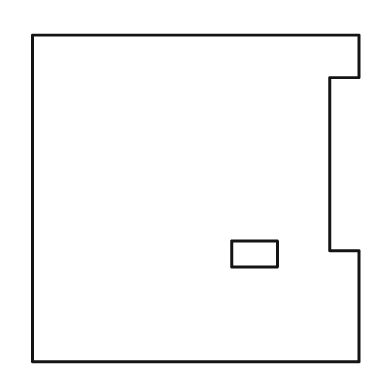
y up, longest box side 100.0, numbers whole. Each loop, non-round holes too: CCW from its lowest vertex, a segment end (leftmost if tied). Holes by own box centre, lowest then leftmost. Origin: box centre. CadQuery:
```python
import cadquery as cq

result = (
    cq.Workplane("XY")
    .moveTo(-50.0, -50.0)
    .lineTo(50.0, -50.0)
    .lineTo(50.0, -16.0)
    .lineTo(41.0, -16.0)
    .lineTo(41.0, 37.0)
    .lineTo(50.0, 37.0)
    .lineTo(50.0, 50.0)
    .lineTo(-50.0, 50.0)
    .close()
    .moveTo(11.0, -21.0)
    .lineTo(25.0, -21.0)
    .lineTo(25.0, -13.0)
    .lineTo(11.0, -13.0)
    .close()
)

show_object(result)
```